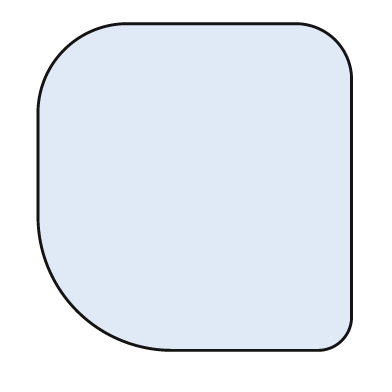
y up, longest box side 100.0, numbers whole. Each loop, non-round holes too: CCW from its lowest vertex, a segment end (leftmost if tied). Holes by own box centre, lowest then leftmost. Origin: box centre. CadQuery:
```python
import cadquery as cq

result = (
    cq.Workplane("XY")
    .moveTo(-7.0, -50.0)
    .lineTo(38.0, -50.0)
    .threePointArc((45.0, -47.0), (48.0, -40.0))
    .lineTo(48.0, 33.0)
    .threePointArc((43.0, 45.0), (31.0, 50.0))
    .lineTo(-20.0, 50.0)
    .threePointArc((-40.0, 42.0), (-48.0, 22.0))
    .lineTo(-48.0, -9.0)
    .threePointArc((-36.0, -38.0), (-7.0, -50.0))
    .close()
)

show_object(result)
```